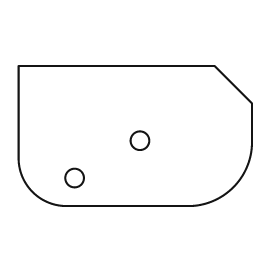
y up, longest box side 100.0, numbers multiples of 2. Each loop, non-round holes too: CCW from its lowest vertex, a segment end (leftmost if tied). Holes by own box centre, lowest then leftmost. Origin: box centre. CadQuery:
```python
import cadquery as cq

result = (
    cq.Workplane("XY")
    .moveTo(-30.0, -30.0)
    .lineTo(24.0, -30.0)
    .threePointArc((42.0, -22.0), (50.0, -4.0))
    .lineTo(50.0, 14.0)
    .lineTo(34.0, 30.0)
    .lineTo(-50.0, 30.0)
    .lineTo(-50.0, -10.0)
    .threePointArc((-44.0, -24.0), (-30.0, -30.0))
    .close()
    .moveTo(-26.0, -18.0)
    .circle(4.0)
    .moveTo(2.0, -2.0)
    .circle(4.0)
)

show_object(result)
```